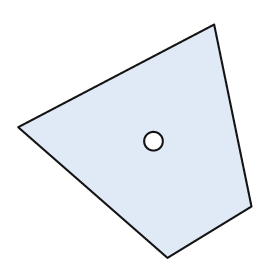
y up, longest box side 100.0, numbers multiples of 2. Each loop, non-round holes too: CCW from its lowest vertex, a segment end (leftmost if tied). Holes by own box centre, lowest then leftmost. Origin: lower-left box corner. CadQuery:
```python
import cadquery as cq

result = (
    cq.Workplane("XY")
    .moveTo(64.0, 0.0)
    .lineTo(100.0, 22.0)
    .lineTo(84.0, 100.0)
    .lineTo(0.0, 56.0)
    .close()
    .moveTo(58.0, 50.0)
    .circle(4.0)
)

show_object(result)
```